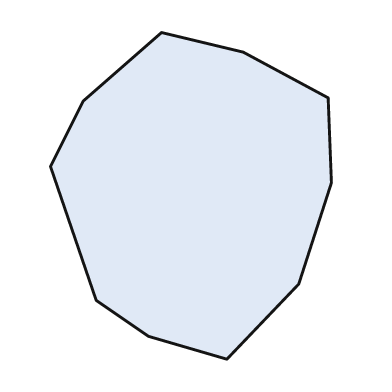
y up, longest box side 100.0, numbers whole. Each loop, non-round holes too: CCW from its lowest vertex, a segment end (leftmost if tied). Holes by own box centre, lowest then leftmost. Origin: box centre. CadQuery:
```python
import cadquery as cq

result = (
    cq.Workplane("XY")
    .moveTo(11.0, -50.0)
    .lineTo(33.0, -27.0)
    .lineTo(43.0, 4.0)
    .lineTo(42.0, 30.0)
    .lineTo(16.0, 44.0)
    .lineTo(-9.0, 50.0)
    .lineTo(-33.0, 29.0)
    .lineTo(-43.0, 9.0)
    .lineTo(-29.0, -32.0)
    .lineTo(-13.0, -43.0)
    .close()
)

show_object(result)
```